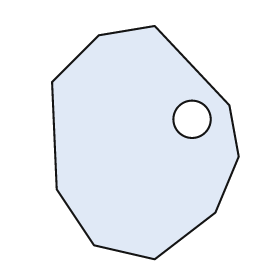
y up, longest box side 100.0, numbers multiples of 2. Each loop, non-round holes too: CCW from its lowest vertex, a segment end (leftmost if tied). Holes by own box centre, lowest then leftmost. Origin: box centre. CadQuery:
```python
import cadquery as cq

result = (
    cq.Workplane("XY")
    .moveTo(4.0, -50.0)
    .lineTo(30.0, -30.0)
    .lineTo(40.0, -6.0)
    .lineTo(36.0, 16.0)
    .lineTo(4.0, 50.0)
    .lineTo(-20.0, 46.0)
    .lineTo(-40.0, 26.0)
    .lineTo(-38.0, -20.0)
    .lineTo(-22.0, -44.0)
    .close()
    .moveTo(20.0, 10.0)
    .circle(8.0)
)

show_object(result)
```